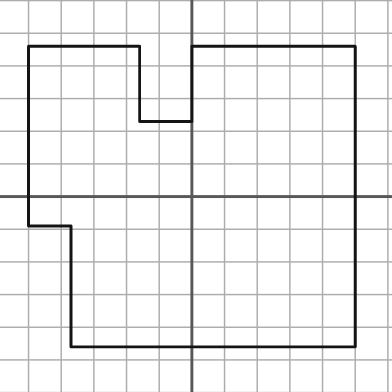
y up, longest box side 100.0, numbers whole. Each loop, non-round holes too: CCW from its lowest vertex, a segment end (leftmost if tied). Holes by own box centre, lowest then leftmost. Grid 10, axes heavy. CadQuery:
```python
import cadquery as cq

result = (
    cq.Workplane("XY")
    .moveTo(-37.0, -46.0)
    .lineTo(50.0, -46.0)
    .lineTo(50.0, 46.0)
    .lineTo(0.0, 46.0)
    .lineTo(0.0, 23.0)
    .lineTo(-16.0, 23.0)
    .lineTo(-16.0, 46.0)
    .lineTo(-50.0, 46.0)
    .lineTo(-50.0, -9.0)
    .lineTo(-37.0, -9.0)
    .close()
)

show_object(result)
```